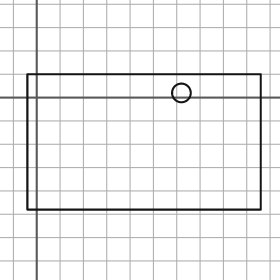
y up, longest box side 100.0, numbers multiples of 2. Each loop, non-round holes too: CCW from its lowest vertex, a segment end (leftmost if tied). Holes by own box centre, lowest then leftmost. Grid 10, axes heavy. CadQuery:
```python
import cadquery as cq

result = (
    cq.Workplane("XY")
    .moveTo(-4.0, -48.0)
    .lineTo(96.0, -48.0)
    .lineTo(96.0, 10.0)
    .lineTo(-4.0, 10.0)
    .close()
    .moveTo(62.0, 2.0)
    .circle(4.0)
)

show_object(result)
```